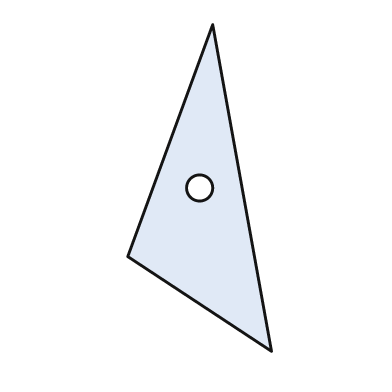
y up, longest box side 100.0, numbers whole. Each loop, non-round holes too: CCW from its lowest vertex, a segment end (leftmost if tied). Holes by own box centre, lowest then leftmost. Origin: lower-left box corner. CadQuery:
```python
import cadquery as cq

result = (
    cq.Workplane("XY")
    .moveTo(44.0, 0.0)
    .lineTo(26.0, 100.0)
    .lineTo(0.0, 29.0)
    .close()
    .moveTo(22.0, 50.0)
    .circle(4.0)
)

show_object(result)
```